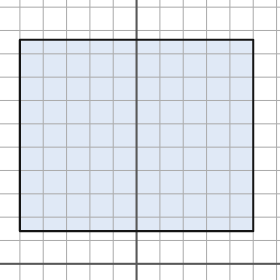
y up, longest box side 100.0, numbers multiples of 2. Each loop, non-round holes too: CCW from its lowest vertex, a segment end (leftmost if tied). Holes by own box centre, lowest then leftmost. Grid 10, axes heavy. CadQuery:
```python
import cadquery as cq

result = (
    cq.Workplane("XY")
    .moveTo(-50.0, 14.0)
    .lineTo(50.0, 14.0)
    .lineTo(50.0, 96.0)
    .lineTo(-50.0, 96.0)
    .close()
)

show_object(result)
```